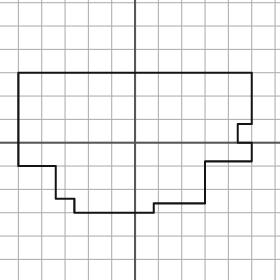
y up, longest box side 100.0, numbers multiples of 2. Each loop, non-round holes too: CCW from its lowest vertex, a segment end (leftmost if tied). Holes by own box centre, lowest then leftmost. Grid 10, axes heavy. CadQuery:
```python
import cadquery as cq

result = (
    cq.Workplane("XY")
    .moveTo(-26.0, -30.0)
    .lineTo(8.0, -30.0)
    .lineTo(8.0, -26.0)
    .lineTo(30.0, -26.0)
    .lineTo(30.0, -8.0)
    .lineTo(50.0, -8.0)
    .lineTo(50.0, 0.0)
    .lineTo(44.0, 0.0)
    .lineTo(44.0, 8.0)
    .lineTo(50.0, 8.0)
    .lineTo(50.0, 30.0)
    .lineTo(-50.0, 30.0)
    .lineTo(-50.0, -10.0)
    .lineTo(-34.0, -10.0)
    .lineTo(-34.0, -24.0)
    .lineTo(-26.0, -24.0)
    .close()
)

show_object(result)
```